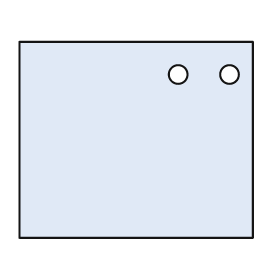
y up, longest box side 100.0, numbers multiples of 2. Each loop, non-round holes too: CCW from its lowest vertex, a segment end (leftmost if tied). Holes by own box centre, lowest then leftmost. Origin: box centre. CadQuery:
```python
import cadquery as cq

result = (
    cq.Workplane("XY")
    .moveTo(-50.0, -42.0)
    .lineTo(50.0, -42.0)
    .lineTo(50.0, 42.0)
    .lineTo(-50.0, 42.0)
    .close()
    .moveTo(18.0, 28.0)
    .circle(4.0)
    .moveTo(40.0, 28.0)
    .circle(4.0)
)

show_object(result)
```